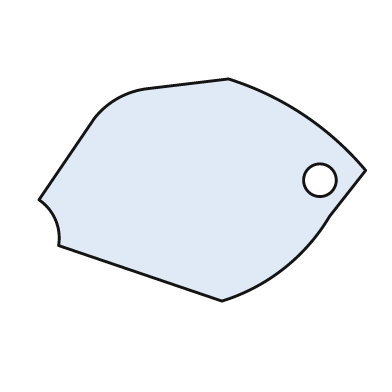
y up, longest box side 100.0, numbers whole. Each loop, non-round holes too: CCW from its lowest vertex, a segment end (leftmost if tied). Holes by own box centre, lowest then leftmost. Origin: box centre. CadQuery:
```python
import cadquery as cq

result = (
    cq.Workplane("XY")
    .moveTo(6.0, -34.0)
    .threePointArc((25.0, -24.0), (39.0, -8.0))
    .lineTo(50.0, 6.0)
    .threePointArc((31.0, 23.0), (8.0, 34.0))
    .lineTo(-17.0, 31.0)
    .threePointArc((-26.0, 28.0), (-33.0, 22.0))
    .lineTo(-50.0, -3.0)
    .threePointArc((-45.0, -9.0), (-44.0, -17.0))
    .close()
    .moveTo(36.0, 3.0)
    .circle(5.0)
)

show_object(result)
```